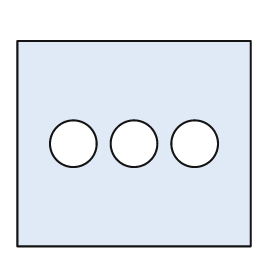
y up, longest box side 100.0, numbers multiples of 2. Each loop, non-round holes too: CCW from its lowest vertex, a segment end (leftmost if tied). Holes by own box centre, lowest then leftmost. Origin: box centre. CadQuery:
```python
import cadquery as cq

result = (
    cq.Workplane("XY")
    .moveTo(-50.0, -44.0)
    .lineTo(50.0, -44.0)
    .lineTo(50.0, 44.0)
    .lineTo(-50.0, 44.0)
    .close()
    .moveTo(-26.0, 0.0)
    .circle(10.0)
    .moveTo(0.0, 0.0)
    .circle(10.0)
    .moveTo(26.0, 0.0)
    .circle(10.0)
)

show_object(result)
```